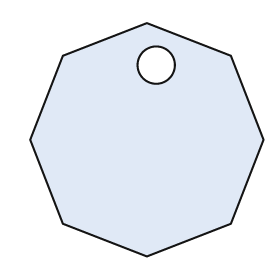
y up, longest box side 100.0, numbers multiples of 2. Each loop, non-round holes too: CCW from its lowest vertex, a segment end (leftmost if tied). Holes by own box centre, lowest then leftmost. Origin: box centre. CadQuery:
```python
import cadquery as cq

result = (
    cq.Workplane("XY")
    .moveTo(0.0, -50.0)
    .lineTo(36.0, -36.0)
    .lineTo(50.0, 0.0)
    .lineTo(36.0, 36.0)
    .lineTo(0.0, 50.0)
    .lineTo(-36.0, 36.0)
    .lineTo(-50.0, 0.0)
    .lineTo(-36.0, -36.0)
    .close()
    .moveTo(4.0, 32.0)
    .circle(8.0)
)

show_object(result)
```